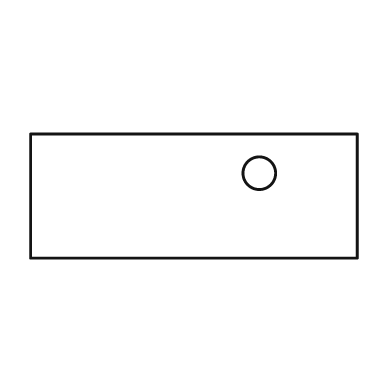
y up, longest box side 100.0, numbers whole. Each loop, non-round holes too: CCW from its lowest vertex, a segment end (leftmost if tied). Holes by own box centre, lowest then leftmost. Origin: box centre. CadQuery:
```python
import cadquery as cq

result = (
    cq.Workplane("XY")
    .moveTo(-50.0, -19.0)
    .lineTo(50.0, -19.0)
    .lineTo(50.0, 19.0)
    .lineTo(-50.0, 19.0)
    .close()
    .moveTo(20.0, 7.0)
    .circle(5.0)
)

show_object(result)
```